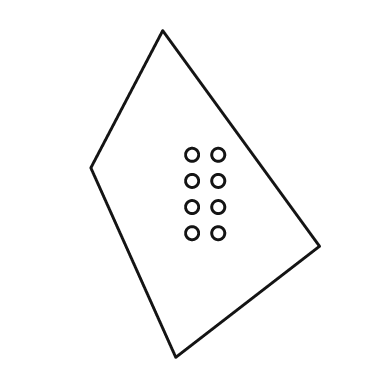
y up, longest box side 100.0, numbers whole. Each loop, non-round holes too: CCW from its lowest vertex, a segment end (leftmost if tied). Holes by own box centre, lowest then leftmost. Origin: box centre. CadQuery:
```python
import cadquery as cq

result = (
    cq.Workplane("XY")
    .moveTo(-9.0, -50.0)
    .lineTo(35.0, -16.0)
    .lineTo(-13.0, 50.0)
    .lineTo(-35.0, 8.0)
    .close()
    .moveTo(-4.0, -12.0)
    .circle(2.0)
    .moveTo(4.0, -12.0)
    .circle(2.0)
    .moveTo(-4.0, -4.0)
    .circle(2.0)
    .moveTo(4.0, -4.0)
    .circle(2.0)
    .moveTo(-4.0, 4.0)
    .circle(2.0)
    .moveTo(4.0, 4.0)
    .circle(2.0)
    .moveTo(-4.0, 12.0)
    .circle(2.0)
    .moveTo(4.0, 12.0)
    .circle(2.0)
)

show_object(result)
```